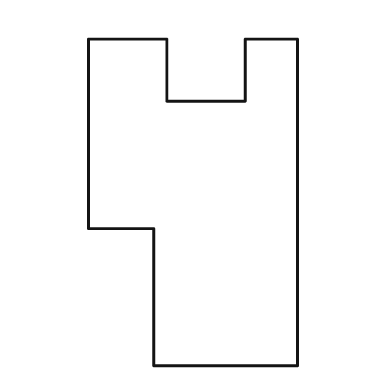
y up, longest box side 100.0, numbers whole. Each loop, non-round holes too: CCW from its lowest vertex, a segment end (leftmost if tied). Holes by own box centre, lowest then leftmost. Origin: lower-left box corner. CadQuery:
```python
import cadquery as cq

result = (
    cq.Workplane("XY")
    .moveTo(20.0, 0.0)
    .lineTo(64.0, 0.0)
    .lineTo(64.0, 100.0)
    .lineTo(48.0, 100.0)
    .lineTo(48.0, 81.0)
    .lineTo(24.0, 81.0)
    .lineTo(24.0, 100.0)
    .lineTo(0.0, 100.0)
    .lineTo(0.0, 42.0)
    .lineTo(20.0, 42.0)
    .close()
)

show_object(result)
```